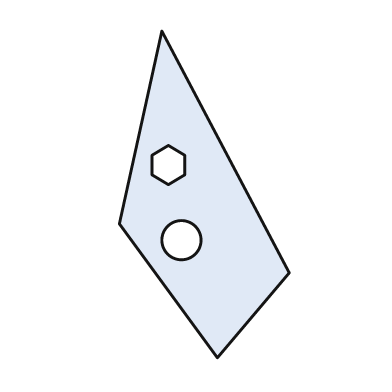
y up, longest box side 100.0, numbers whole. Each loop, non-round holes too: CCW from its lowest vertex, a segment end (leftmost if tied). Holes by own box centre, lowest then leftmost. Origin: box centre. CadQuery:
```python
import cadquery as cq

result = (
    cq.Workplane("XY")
    .moveTo(4.0, -50.0)
    .lineTo(26.0, -24.0)
    .lineTo(-13.0, 50.0)
    .lineTo(-26.0, -9.0)
    .close()
    .moveTo(-7.0, -14.0)
    .circle(6.0)
    .moveTo(-11.0, 3.0)
    .lineTo(-6.0, 6.0)
    .lineTo(-6.0, 12.0)
    .lineTo(-11.0, 15.0)
    .lineTo(-16.0, 12.0)
    .lineTo(-16.0, 6.0)
    .close()
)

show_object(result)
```